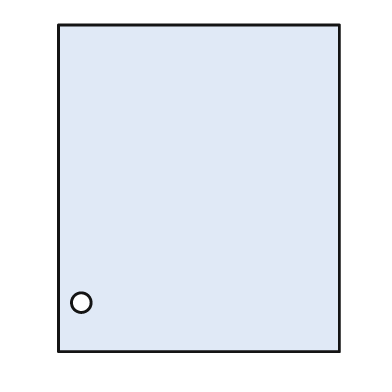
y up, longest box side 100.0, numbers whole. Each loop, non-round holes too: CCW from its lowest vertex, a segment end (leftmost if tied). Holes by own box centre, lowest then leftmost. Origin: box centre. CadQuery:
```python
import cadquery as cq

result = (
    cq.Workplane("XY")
    .moveTo(-43.0, -50.0)
    .lineTo(43.0, -50.0)
    .lineTo(43.0, 50.0)
    .lineTo(-43.0, 50.0)
    .close()
    .moveTo(-36.0, -35.0)
    .circle(3.0)
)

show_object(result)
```